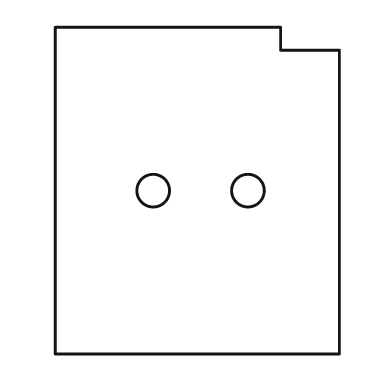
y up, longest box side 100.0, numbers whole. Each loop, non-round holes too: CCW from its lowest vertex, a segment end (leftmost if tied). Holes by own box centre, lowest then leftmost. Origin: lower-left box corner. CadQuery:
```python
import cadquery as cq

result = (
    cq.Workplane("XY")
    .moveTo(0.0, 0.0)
    .lineTo(87.0, 0.0)
    .lineTo(87.0, 93.0)
    .lineTo(69.0, 93.0)
    .lineTo(69.0, 100.0)
    .lineTo(0.0, 100.0)
    .close()
    .moveTo(30.0, 50.0)
    .circle(5.0)
    .moveTo(59.0, 50.0)
    .circle(5.0)
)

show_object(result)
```